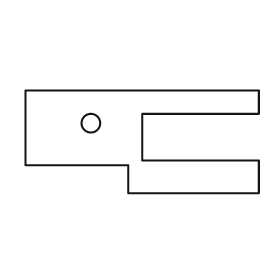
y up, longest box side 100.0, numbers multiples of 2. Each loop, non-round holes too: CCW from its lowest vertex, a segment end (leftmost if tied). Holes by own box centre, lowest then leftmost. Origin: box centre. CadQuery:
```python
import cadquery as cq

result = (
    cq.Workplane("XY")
    .moveTo(-6.0, -22.0)
    .lineTo(50.0, -22.0)
    .lineTo(50.0, -8.0)
    .lineTo(0.0, -8.0)
    .lineTo(0.0, 12.0)
    .lineTo(50.0, 12.0)
    .lineTo(50.0, 22.0)
    .lineTo(-50.0, 22.0)
    .lineTo(-50.0, -10.0)
    .lineTo(-6.0, -10.0)
    .close()
    .moveTo(-22.0, 8.0)
    .circle(4.0)
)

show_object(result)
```